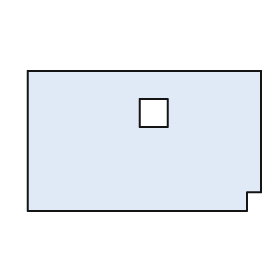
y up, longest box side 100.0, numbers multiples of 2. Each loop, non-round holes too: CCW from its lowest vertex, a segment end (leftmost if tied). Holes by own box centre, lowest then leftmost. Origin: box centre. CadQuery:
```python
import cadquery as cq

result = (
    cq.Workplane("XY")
    .moveTo(-50.0, -30.0)
    .lineTo(44.0, -30.0)
    .lineTo(44.0, -22.0)
    .lineTo(50.0, -22.0)
    .lineTo(50.0, 30.0)
    .lineTo(-50.0, 30.0)
    .close()
    .moveTo(-2.0, 6.0)
    .lineTo(10.0, 6.0)
    .lineTo(10.0, 18.0)
    .lineTo(-2.0, 18.0)
    .close()
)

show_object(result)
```